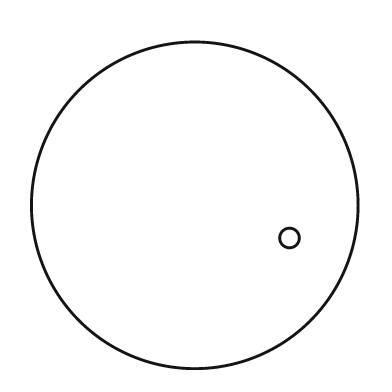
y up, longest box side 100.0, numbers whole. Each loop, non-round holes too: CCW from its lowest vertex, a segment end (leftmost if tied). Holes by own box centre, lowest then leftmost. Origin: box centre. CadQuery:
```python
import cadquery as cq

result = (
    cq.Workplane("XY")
    .moveTo(0.0, 0.0)
    .circle(50.0)
    .moveTo(29.0, -10.0)
    .circle(3.0)
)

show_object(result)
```